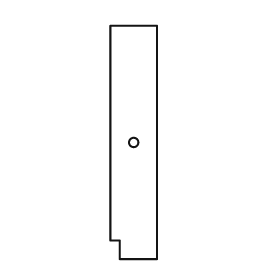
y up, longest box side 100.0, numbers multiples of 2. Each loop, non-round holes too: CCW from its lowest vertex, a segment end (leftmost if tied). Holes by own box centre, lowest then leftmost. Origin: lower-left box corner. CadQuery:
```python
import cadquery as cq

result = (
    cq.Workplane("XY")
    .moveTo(4.0, 0.0)
    .lineTo(20.0, 0.0)
    .lineTo(20.0, 100.0)
    .lineTo(0.0, 100.0)
    .lineTo(0.0, 8.0)
    .lineTo(4.0, 8.0)
    .close()
    .moveTo(10.0, 50.0)
    .circle(2.0)
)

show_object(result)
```